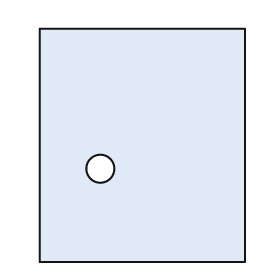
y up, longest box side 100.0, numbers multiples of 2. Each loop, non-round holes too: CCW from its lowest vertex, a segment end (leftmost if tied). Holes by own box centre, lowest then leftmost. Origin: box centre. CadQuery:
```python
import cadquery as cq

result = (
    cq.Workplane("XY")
    .moveTo(-44.0, -50.0)
    .lineTo(44.0, -50.0)
    .lineTo(44.0, 50.0)
    .lineTo(-44.0, 50.0)
    .close()
    .moveTo(-18.0, -10.0)
    .circle(6.0)
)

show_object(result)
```